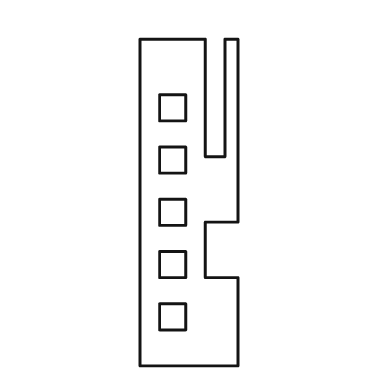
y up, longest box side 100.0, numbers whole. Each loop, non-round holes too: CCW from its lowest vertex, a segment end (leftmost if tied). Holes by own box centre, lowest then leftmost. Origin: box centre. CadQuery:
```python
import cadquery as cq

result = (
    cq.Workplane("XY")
    .moveTo(-15.0, -50.0)
    .lineTo(15.0, -50.0)
    .lineTo(15.0, -23.0)
    .lineTo(5.0, -23.0)
    .lineTo(5.0, -6.0)
    .lineTo(15.0, -6.0)
    .lineTo(15.0, 50.0)
    .lineTo(11.0, 50.0)
    .lineTo(11.0, 14.0)
    .lineTo(5.0, 14.0)
    .lineTo(5.0, 50.0)
    .lineTo(-15.0, 50.0)
    .close()
    .moveTo(-9.0, -39.0)
    .lineTo(-1.0, -39.0)
    .lineTo(-1.0, -31.0)
    .lineTo(-9.0, -31.0)
    .close()
    .moveTo(-9.0, -23.0)
    .lineTo(-1.0, -23.0)
    .lineTo(-1.0, -15.0)
    .lineTo(-9.0, -15.0)
    .close()
    .moveTo(-9.0, -7.0)
    .lineTo(-1.0, -7.0)
    .lineTo(-1.0, 1.0)
    .lineTo(-9.0, 1.0)
    .close()
    .moveTo(-9.0, 9.0)
    .lineTo(-1.0, 9.0)
    .lineTo(-1.0, 17.0)
    .lineTo(-9.0, 17.0)
    .close()
    .moveTo(-9.0, 25.0)
    .lineTo(-1.0, 25.0)
    .lineTo(-1.0, 33.0)
    .lineTo(-9.0, 33.0)
    .close()
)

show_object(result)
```